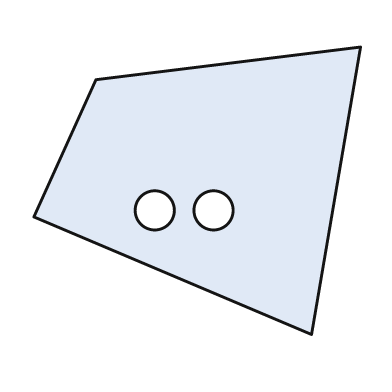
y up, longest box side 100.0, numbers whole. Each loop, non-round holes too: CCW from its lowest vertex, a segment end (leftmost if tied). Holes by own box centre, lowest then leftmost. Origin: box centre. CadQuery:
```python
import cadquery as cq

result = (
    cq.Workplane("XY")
    .moveTo(35.0, -44.0)
    .lineTo(50.0, 44.0)
    .lineTo(-31.0, 34.0)
    .lineTo(-50.0, -8.0)
    .close()
    .moveTo(-13.0, -6.0)
    .circle(6.0)
    .moveTo(5.0, -6.0)
    .circle(6.0)
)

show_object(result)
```